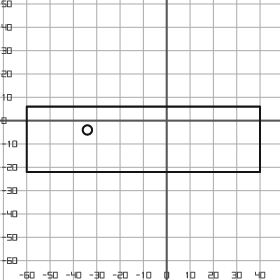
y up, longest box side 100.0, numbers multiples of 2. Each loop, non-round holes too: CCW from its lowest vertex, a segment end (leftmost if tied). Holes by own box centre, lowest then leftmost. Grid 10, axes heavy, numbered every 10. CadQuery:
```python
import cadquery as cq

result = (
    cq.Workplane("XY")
    .moveTo(-60.0, -22.0)
    .lineTo(40.0, -22.0)
    .lineTo(40.0, 6.0)
    .lineTo(-60.0, 6.0)
    .close()
    .moveTo(-34.0, -4.0)
    .circle(2.0)
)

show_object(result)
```